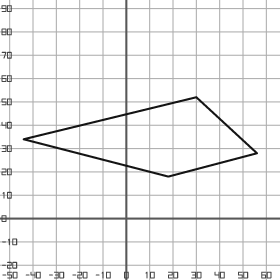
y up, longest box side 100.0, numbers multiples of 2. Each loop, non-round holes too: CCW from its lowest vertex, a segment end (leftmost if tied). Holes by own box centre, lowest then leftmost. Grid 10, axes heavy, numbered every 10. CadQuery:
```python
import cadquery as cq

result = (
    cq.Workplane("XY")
    .moveTo(18.0, 18.0)
    .lineTo(56.0, 28.0)
    .lineTo(30.0, 52.0)
    .lineTo(-44.0, 34.0)
    .close()
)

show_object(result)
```